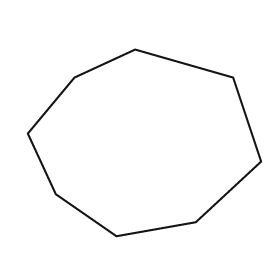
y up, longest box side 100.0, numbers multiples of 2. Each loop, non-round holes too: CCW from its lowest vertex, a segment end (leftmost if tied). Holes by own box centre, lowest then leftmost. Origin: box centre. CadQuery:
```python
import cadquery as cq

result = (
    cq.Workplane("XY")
    .moveTo(-12.0, -40.0)
    .lineTo(22.0, -34.0)
    .lineTo(50.0, -8.0)
    .lineTo(38.0, 28.0)
    .lineTo(-4.0, 40.0)
    .lineTo(-30.0, 28.0)
    .lineTo(-50.0, 4.0)
    .lineTo(-38.0, -22.0)
    .close()
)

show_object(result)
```